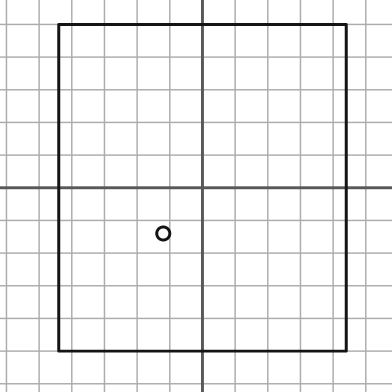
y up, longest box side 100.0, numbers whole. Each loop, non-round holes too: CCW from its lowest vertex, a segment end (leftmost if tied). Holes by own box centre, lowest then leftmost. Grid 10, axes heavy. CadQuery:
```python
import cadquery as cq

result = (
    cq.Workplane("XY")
    .moveTo(-44.0, -50.0)
    .lineTo(44.0, -50.0)
    .lineTo(44.0, 50.0)
    .lineTo(-44.0, 50.0)
    .close()
    .moveTo(-12.0, -14.0)
    .circle(2.0)
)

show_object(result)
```